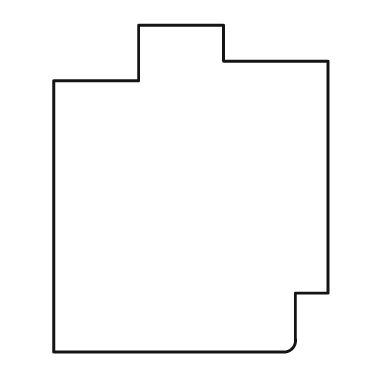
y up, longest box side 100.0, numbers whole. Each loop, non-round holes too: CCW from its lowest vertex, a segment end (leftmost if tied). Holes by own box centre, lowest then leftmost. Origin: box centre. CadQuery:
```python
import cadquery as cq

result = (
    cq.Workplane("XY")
    .moveTo(-42.0, -50.0)
    .lineTo(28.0, -50.0)
    .threePointArc((31.0, -49.0), (32.0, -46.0))
    .lineTo(32.0, -32.0)
    .lineTo(42.0, -32.0)
    .lineTo(42.0, 39.0)
    .lineTo(10.0, 39.0)
    .lineTo(10.0, 50.0)
    .lineTo(-16.0, 50.0)
    .lineTo(-16.0, 33.0)
    .lineTo(-42.0, 33.0)
    .close()
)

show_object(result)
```